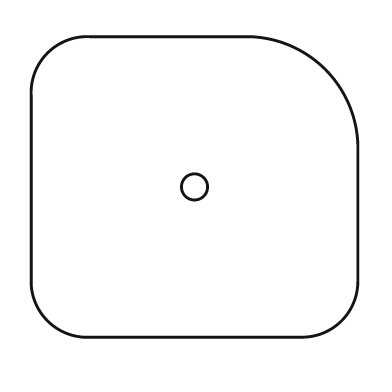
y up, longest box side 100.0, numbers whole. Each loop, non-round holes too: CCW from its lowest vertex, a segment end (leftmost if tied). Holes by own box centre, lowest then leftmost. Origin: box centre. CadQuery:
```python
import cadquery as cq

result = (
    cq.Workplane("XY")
    .moveTo(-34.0, -46.0)
    .lineTo(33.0, -46.0)
    .threePointArc((45.0, -41.0), (50.0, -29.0))
    .lineTo(50.0, 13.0)
    .threePointArc((40.0, 36.0), (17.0, 46.0))
    .lineTo(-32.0, 46.0)
    .threePointArc((-45.0, 41.0), (-50.0, 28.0))
    .lineTo(-50.0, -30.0)
    .threePointArc((-45.0, -41.0), (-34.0, -46.0))
    .close()
    .moveTo(0.0, 0.0)
    .circle(4.0)
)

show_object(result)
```